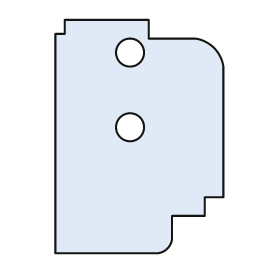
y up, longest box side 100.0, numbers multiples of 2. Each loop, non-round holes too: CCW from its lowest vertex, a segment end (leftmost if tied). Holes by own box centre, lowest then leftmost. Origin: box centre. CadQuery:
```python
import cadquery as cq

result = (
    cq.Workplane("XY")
    .moveTo(-36.0, -50.0)
    .lineTo(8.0, -50.0)
    .threePointArc((12.0, -48.0), (14.0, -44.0))
    .lineTo(14.0, -34.0)
    .lineTo(28.0, -34.0)
    .lineTo(28.0, -26.0)
    .lineTo(36.0, -26.0)
    .lineTo(36.0, 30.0)
    .threePointArc((32.0, 38.0), (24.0, 42.0))
    .lineTo(4.0, 42.0)
    .lineTo(4.0, 50.0)
    .lineTo(-32.0, 50.0)
    .lineTo(-32.0, 44.0)
    .lineTo(-36.0, 44.0)
    .close()
    .moveTo(-4.0, 4.0)
    .circle(6.0)
    .moveTo(-4.0, 36.0)
    .circle(6.0)
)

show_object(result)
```